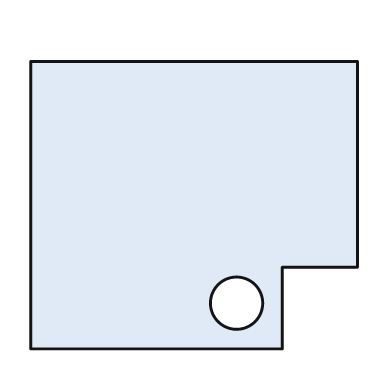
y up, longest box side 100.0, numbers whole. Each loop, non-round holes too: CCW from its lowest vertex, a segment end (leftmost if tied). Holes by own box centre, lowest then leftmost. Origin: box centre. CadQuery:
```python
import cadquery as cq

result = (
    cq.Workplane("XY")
    .moveTo(-50.0, -44.0)
    .lineTo(27.0, -44.0)
    .lineTo(27.0, -19.0)
    .lineTo(50.0, -19.0)
    .lineTo(50.0, 44.0)
    .lineTo(-50.0, 44.0)
    .close()
    .moveTo(13.0, -30.0)
    .circle(8.0)
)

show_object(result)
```